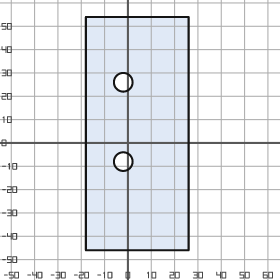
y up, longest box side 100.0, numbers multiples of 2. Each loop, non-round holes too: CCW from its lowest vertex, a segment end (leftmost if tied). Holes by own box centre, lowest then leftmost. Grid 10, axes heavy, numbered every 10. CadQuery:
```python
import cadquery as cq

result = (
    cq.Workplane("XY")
    .moveTo(-18.0, -46.0)
    .lineTo(26.0, -46.0)
    .lineTo(26.0, 54.0)
    .lineTo(-18.0, 54.0)
    .close()
    .moveTo(-2.0, -8.0)
    .circle(4.0)
    .moveTo(-2.0, 26.0)
    .circle(4.0)
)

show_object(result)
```